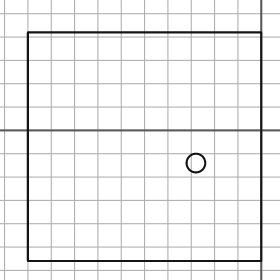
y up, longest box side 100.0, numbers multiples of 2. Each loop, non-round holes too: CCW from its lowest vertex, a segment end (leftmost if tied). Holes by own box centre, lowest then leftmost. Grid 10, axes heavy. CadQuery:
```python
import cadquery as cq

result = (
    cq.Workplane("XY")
    .moveTo(-100.0, -56.0)
    .lineTo(0.0, -56.0)
    .lineTo(0.0, 42.0)
    .lineTo(-100.0, 42.0)
    .close()
    .moveTo(-28.0, -14.0)
    .circle(4.0)
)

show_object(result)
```